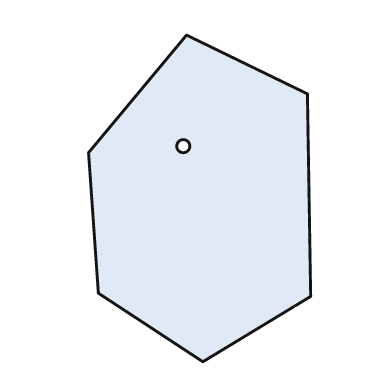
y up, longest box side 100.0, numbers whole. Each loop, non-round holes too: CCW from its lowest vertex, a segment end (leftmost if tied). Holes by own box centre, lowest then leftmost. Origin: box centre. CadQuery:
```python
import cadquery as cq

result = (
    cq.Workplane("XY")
    .moveTo(1.0, -50.0)
    .lineTo(34.0, -30.0)
    .lineTo(33.0, 32.0)
    .lineTo(-4.0, 50.0)
    .lineTo(-34.0, 14.0)
    .lineTo(-31.0, -29.0)
    .close()
    .moveTo(-5.0, 16.0)
    .circle(2.0)
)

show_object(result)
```